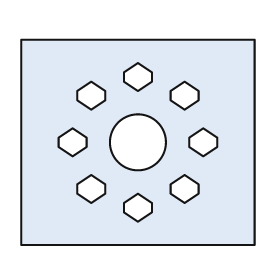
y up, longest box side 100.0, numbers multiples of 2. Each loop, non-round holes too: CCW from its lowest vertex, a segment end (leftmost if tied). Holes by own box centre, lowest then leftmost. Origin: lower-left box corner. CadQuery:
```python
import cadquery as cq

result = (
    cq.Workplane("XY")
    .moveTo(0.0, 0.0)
    .lineTo(100.0, 0.0)
    .lineTo(100.0, 88.0)
    .lineTo(0.0, 88.0)
    .close()
    .moveTo(50.0, 10.0)
    .lineTo(56.0, 14.0)
    .lineTo(56.0, 18.0)
    .lineTo(50.0, 22.0)
    .lineTo(44.0, 18.0)
    .lineTo(44.0, 14.0)
    .close()
    .moveTo(30.0, 18.0)
    .lineTo(36.0, 22.0)
    .lineTo(36.0, 26.0)
    .lineTo(30.0, 30.0)
    .lineTo(24.0, 26.0)
    .lineTo(24.0, 22.0)
    .close()
    .moveTo(70.0, 18.0)
    .lineTo(76.0, 22.0)
    .lineTo(76.0, 26.0)
    .lineTo(70.0, 30.0)
    .lineTo(64.0, 26.0)
    .lineTo(64.0, 22.0)
    .close()
    .moveTo(22.0, 38.0)
    .lineTo(28.0, 42.0)
    .lineTo(28.0, 46.0)
    .lineTo(22.0, 50.0)
    .lineTo(16.0, 46.0)
    .lineTo(16.0, 42.0)
    .close()
    .moveTo(50.0, 44.0)
    .circle(12.0)
    .moveTo(78.0, 38.0)
    .lineTo(84.0, 42.0)
    .lineTo(84.0, 46.0)
    .lineTo(78.0, 50.0)
    .lineTo(72.0, 46.0)
    .lineTo(72.0, 42.0)
    .close()
    .moveTo(30.0, 58.0)
    .lineTo(36.0, 62.0)
    .lineTo(36.0, 66.0)
    .lineTo(30.0, 70.0)
    .lineTo(24.0, 66.0)
    .lineTo(24.0, 62.0)
    .close()
    .moveTo(70.0, 58.0)
    .lineTo(76.0, 62.0)
    .lineTo(76.0, 66.0)
    .lineTo(70.0, 70.0)
    .lineTo(64.0, 66.0)
    .lineTo(64.0, 62.0)
    .close()
    .moveTo(50.0, 66.0)
    .lineTo(56.0, 70.0)
    .lineTo(56.0, 74.0)
    .lineTo(50.0, 78.0)
    .lineTo(44.0, 74.0)
    .lineTo(44.0, 70.0)
    .close()
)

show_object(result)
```